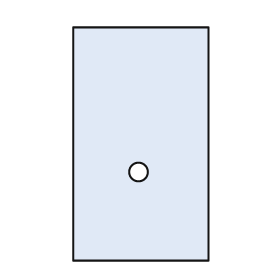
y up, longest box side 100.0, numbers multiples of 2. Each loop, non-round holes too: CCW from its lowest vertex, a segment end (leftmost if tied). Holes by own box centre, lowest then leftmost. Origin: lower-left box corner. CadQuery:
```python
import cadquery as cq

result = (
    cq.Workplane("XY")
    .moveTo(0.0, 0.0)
    .lineTo(58.0, 0.0)
    .lineTo(58.0, 100.0)
    .lineTo(0.0, 100.0)
    .close()
    .moveTo(28.0, 38.0)
    .circle(4.0)
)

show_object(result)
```